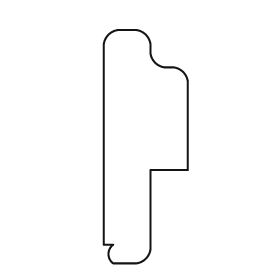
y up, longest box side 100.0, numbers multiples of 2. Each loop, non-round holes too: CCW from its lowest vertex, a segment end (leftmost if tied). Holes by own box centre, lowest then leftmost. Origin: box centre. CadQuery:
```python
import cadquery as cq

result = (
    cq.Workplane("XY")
    .moveTo(-14.0, -50.0)
    .lineTo(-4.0, -50.0)
    .threePointArc((0.0, -48.0), (2.0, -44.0))
    .lineTo(2.0, -10.0)
    .lineTo(18.0, -10.0)
    .lineTo(18.0, 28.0)
    .threePointArc((16.0, 32.0), (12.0, 34.0))
    .lineTo(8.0, 34.0)
    .threePointArc((4.0, 36.0), (2.0, 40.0))
    .lineTo(2.0, 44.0)
    .threePointArc((0.0, 48.0), (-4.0, 50.0))
    .lineTo(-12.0, 50.0)
    .threePointArc((-16.0, 48.0), (-18.0, 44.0))
    .lineTo(-18.0, -42.0)
    .lineTo(-14.0, -42.0)
    .threePointArc((-16.0, -46.0), (-14.0, -50.0))
    .close()
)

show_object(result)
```